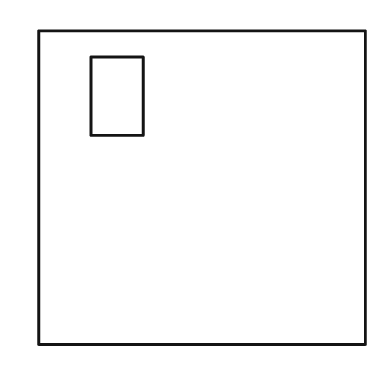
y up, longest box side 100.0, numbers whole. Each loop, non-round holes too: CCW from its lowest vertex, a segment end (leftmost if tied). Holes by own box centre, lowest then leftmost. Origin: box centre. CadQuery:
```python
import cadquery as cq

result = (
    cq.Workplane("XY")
    .moveTo(-50.0, -48.0)
    .lineTo(50.0, -48.0)
    .lineTo(50.0, 48.0)
    .lineTo(-50.0, 48.0)
    .close()
    .moveTo(-34.0, 16.0)
    .lineTo(-18.0, 16.0)
    .lineTo(-18.0, 40.0)
    .lineTo(-34.0, 40.0)
    .close()
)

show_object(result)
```